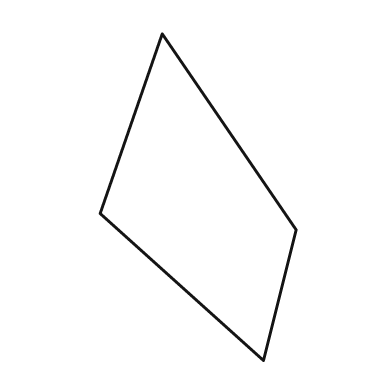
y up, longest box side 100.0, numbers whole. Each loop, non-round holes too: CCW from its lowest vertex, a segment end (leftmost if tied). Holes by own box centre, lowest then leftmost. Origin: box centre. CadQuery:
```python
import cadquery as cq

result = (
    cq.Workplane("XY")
    .moveTo(20.0, -50.0)
    .lineTo(30.0, -10.0)
    .lineTo(-11.0, 50.0)
    .lineTo(-30.0, -5.0)
    .close()
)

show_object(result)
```